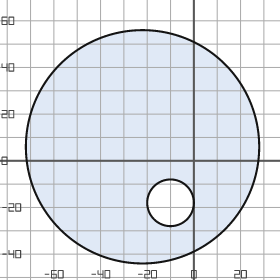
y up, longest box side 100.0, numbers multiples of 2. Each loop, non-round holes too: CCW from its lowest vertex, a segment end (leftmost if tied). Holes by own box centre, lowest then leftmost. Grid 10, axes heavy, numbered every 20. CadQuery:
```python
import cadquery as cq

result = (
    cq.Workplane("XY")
    .moveTo(-22.0, 6.0)
    .circle(50.0)
    .moveTo(-10.0, -18.0)
    .circle(10.0)
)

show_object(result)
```